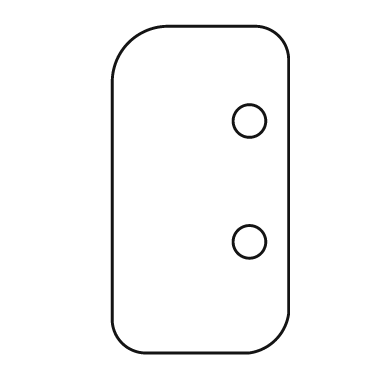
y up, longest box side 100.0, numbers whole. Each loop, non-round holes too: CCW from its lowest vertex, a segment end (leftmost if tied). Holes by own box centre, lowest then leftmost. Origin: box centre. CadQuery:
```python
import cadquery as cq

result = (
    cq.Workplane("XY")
    .moveTo(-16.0, -50.0)
    .lineTo(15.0, -50.0)
    .threePointArc((23.0, -46.0), (27.0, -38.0))
    .lineTo(27.0, 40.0)
    .threePointArc((24.0, 47.0), (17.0, 50.0))
    .lineTo(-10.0, 50.0)
    .threePointArc((-22.0, 45.0), (-27.0, 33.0))
    .lineTo(-27.0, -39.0)
    .threePointArc((-24.0, -47.0), (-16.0, -50.0))
    .close()
    .moveTo(15.0, -16.0)
    .circle(5.0)
    .moveTo(15.0, 21.0)
    .circle(5.0)
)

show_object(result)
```